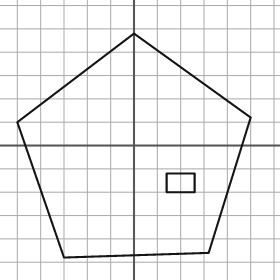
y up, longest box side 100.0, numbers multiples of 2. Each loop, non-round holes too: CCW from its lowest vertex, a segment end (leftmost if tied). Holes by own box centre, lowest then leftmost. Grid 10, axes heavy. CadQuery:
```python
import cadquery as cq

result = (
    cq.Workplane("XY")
    .moveTo(-30.0, -48.0)
    .lineTo(32.0, -46.0)
    .lineTo(50.0, 12.0)
    .lineTo(0.0, 48.0)
    .lineTo(-50.0, 10.0)
    .close()
    .moveTo(14.0, -20.0)
    .lineTo(26.0, -20.0)
    .lineTo(26.0, -12.0)
    .lineTo(14.0, -12.0)
    .close()
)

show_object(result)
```